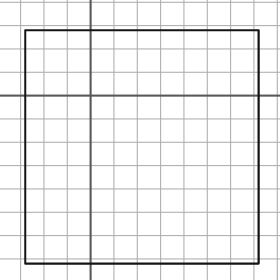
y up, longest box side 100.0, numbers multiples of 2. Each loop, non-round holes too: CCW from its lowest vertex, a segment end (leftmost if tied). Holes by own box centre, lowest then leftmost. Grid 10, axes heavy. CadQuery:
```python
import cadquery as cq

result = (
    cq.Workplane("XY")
    .moveTo(-28.0, -72.0)
    .lineTo(72.0, -72.0)
    .lineTo(72.0, 28.0)
    .lineTo(-28.0, 28.0)
    .close()
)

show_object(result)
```